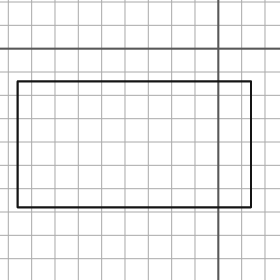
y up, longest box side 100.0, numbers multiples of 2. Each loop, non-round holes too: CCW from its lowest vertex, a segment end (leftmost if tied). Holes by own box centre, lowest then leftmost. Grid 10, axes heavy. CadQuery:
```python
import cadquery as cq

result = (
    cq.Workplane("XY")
    .moveTo(-86.0, -68.0)
    .lineTo(14.0, -68.0)
    .lineTo(14.0, -14.0)
    .lineTo(-86.0, -14.0)
    .close()
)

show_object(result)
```